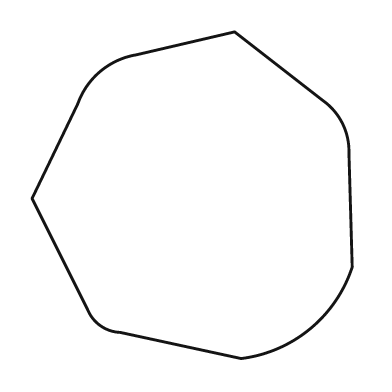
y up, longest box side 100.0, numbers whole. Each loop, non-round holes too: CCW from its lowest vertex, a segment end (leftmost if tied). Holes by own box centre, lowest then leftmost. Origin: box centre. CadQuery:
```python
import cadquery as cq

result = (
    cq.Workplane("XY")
    .moveTo(15.0, -50.0)
    .threePointArc((36.0, -41.0), (49.0, -22.0))
    .lineTo(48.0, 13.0)
    .threePointArc((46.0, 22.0), (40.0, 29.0))
    .lineTo(13.0, 50.0)
    .lineTo(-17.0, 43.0)
    .threePointArc((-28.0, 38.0), (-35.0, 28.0))
    .lineTo(-49.0, -1.0)
    .lineTo(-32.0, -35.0)
    .threePointArc((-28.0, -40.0), (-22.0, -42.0))
    .close()
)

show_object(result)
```